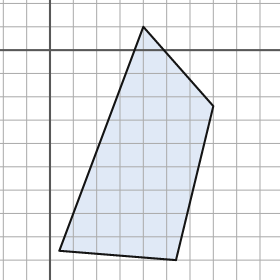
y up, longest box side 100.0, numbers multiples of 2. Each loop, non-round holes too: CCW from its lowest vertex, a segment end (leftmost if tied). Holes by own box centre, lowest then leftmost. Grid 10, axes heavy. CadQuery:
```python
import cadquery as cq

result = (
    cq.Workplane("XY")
    .moveTo(54.0, -90.0)
    .lineTo(70.0, -24.0)
    .lineTo(40.0, 10.0)
    .lineTo(4.0, -86.0)
    .close()
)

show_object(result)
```